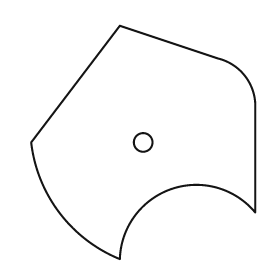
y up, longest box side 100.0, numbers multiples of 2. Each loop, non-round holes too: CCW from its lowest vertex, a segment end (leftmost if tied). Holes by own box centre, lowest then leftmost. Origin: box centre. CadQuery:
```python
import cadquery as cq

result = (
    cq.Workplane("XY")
    .moveTo(-10.0, -50.0)
    .threePointArc((12.0, -20.0), (48.0, -30.0))
    .lineTo(48.0, 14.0)
    .threePointArc((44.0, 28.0), (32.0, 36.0))
    .lineTo(-10.0, 50.0)
    .lineTo(-48.0, 0.0)
    .threePointArc((-36.0, -30.0), (-10.0, -50.0))
    .close()
    .moveTo(0.0, 0.0)
    .circle(4.0)
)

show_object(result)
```